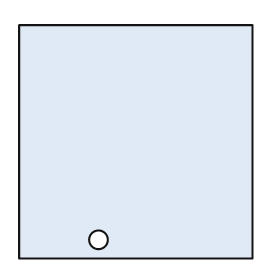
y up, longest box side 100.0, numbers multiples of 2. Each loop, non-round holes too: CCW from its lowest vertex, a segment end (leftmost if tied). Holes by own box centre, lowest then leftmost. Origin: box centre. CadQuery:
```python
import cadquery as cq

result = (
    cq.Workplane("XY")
    .moveTo(-50.0, -50.0)
    .lineTo(50.0, -50.0)
    .lineTo(50.0, 50.0)
    .lineTo(-50.0, 50.0)
    .close()
    .moveTo(-16.0, -42.0)
    .circle(4.0)
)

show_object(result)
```